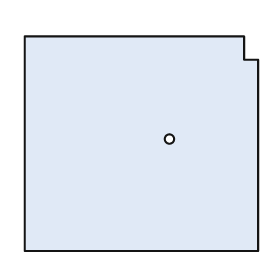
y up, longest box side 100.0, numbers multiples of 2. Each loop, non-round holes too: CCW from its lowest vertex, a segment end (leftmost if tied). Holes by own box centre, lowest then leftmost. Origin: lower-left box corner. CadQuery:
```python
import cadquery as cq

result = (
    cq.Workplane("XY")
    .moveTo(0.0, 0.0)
    .lineTo(100.0, 0.0)
    .lineTo(100.0, 82.0)
    .lineTo(94.0, 82.0)
    .lineTo(94.0, 92.0)
    .lineTo(0.0, 92.0)
    .close()
    .moveTo(62.0, 48.0)
    .circle(2.0)
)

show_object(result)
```